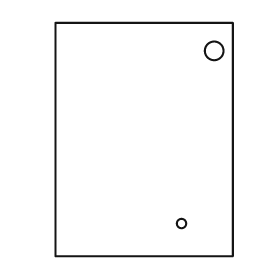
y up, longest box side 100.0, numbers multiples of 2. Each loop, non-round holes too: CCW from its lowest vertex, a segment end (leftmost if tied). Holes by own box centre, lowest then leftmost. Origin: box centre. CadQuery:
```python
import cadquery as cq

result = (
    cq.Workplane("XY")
    .moveTo(-38.0, -50.0)
    .lineTo(38.0, -50.0)
    .lineTo(38.0, 50.0)
    .lineTo(-38.0, 50.0)
    .close()
    .moveTo(16.0, -36.0)
    .circle(2.0)
    .moveTo(30.0, 38.0)
    .circle(4.0)
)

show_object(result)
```